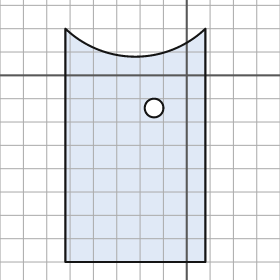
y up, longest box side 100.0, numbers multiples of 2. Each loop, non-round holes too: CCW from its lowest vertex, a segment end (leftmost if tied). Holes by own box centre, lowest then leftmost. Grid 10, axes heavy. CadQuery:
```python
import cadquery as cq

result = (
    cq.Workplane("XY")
    .moveTo(-52.0, -80.0)
    .lineTo(8.0, -80.0)
    .lineTo(8.0, 20.0)
    .threePointArc((-22.0, 8.0), (-52.0, 20.0))
    .close()
    .moveTo(-14.0, -14.0)
    .circle(4.0)
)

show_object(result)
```